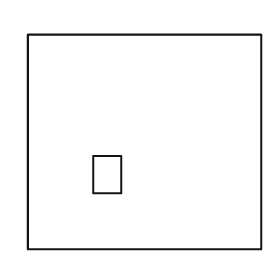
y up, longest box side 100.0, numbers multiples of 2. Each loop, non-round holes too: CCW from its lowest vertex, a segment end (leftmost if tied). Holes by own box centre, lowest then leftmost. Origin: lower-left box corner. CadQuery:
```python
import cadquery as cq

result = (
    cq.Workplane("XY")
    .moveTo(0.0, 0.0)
    .lineTo(100.0, 0.0)
    .lineTo(100.0, 92.0)
    .lineTo(0.0, 92.0)
    .close()
    .moveTo(28.0, 24.0)
    .lineTo(40.0, 24.0)
    .lineTo(40.0, 40.0)
    .lineTo(28.0, 40.0)
    .close()
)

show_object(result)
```